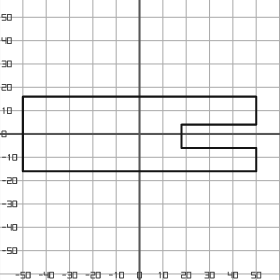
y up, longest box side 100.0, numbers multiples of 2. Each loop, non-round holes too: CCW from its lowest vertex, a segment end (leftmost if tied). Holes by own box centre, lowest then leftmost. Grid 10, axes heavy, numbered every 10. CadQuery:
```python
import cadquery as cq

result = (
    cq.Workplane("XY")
    .moveTo(-50.0, -16.0)
    .lineTo(50.0, -16.0)
    .lineTo(50.0, -6.0)
    .lineTo(18.0, -6.0)
    .lineTo(18.0, 4.0)
    .lineTo(50.0, 4.0)
    .lineTo(50.0, 16.0)
    .lineTo(-50.0, 16.0)
    .close()
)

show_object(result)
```